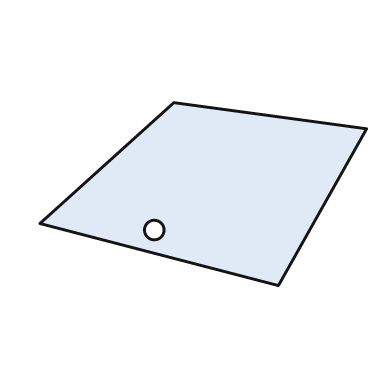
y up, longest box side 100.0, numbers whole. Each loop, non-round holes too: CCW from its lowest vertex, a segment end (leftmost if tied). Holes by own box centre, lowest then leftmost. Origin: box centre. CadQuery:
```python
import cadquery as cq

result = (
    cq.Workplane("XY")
    .moveTo(23.0, -28.0)
    .lineTo(50.0, 20.0)
    .lineTo(-9.0, 28.0)
    .lineTo(-50.0, -9.0)
    .close()
    .moveTo(-15.0, -11.0)
    .circle(3.0)
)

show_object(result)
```